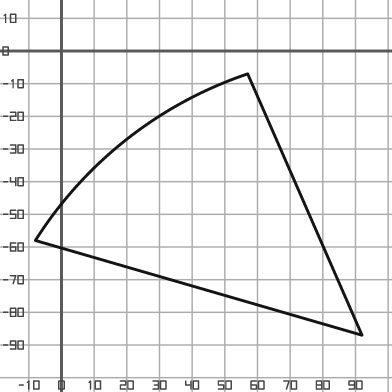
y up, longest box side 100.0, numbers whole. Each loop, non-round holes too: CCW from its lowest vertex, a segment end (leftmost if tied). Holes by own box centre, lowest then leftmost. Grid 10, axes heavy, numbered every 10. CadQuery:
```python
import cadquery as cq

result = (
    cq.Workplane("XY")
    .moveTo(92.0, -87.0)
    .lineTo(57.0, -7.0)
    .threePointArc((20.0, -27.0), (-8.0, -58.0))
    .close()
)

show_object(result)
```